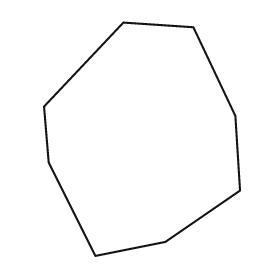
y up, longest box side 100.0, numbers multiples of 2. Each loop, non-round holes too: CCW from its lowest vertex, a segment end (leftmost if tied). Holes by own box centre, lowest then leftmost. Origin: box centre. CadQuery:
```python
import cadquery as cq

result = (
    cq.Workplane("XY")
    .moveTo(-20.0, -50.0)
    .lineTo(10.0, -44.0)
    .lineTo(42.0, -22.0)
    .lineTo(40.0, 10.0)
    .lineTo(22.0, 48.0)
    .lineTo(-8.0, 50.0)
    .lineTo(-42.0, 14.0)
    .lineTo(-40.0, -10.0)
    .close()
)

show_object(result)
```